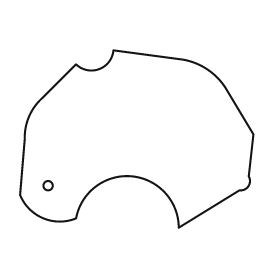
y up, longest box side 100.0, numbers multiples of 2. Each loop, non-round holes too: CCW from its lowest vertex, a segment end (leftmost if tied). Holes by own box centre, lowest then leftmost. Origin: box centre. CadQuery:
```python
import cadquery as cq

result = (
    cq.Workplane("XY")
    .moveTo(18.0, -38.0)
    .lineTo(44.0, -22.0)
    .threePointArc((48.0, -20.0), (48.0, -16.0))
    .lineTo(50.0, 2.0)
    .lineTo(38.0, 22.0)
    .threePointArc((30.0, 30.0), (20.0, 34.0))
    .lineTo(-10.0, 38.0)
    .threePointArc((-16.0, 30.0), (-26.0, 32.0))
    .lineTo(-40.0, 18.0)
    .threePointArc((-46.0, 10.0), (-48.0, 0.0))
    .lineTo(-50.0, -24.0)
    .threePointArc((-40.0, -34.0), (-26.0, -34.0))
    .threePointArc((-2.0, -16.0), (18.0, -38.0))
    .close()
    .moveTo(-38.0, -20.0)
    .circle(2.0)
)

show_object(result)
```